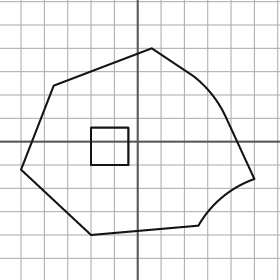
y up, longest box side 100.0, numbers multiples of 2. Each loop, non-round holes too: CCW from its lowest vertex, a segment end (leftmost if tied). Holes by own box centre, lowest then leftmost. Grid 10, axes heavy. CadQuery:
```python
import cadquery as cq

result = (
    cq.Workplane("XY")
    .moveTo(-20.0, -40.0)
    .lineTo(26.0, -36.0)
    .threePointArc((36.0, -24.0), (50.0, -16.0))
    .lineTo(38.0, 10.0)
    .threePointArc((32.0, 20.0), (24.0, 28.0))
    .lineTo(6.0, 40.0)
    .lineTo(-36.0, 24.0)
    .lineTo(-50.0, -12.0)
    .close()
    .moveTo(-20.0, -10.0)
    .lineTo(-4.0, -10.0)
    .lineTo(-4.0, 6.0)
    .lineTo(-20.0, 6.0)
    .close()
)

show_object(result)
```